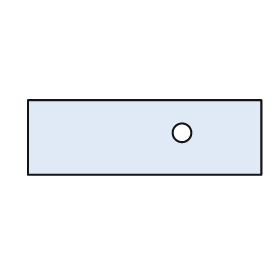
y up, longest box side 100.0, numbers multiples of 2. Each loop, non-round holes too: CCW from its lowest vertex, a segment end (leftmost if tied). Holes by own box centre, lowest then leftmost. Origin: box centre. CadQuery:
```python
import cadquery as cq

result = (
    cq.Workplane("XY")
    .moveTo(-50.0, -16.0)
    .lineTo(50.0, -16.0)
    .lineTo(50.0, 16.0)
    .lineTo(-50.0, 16.0)
    .close()
    .moveTo(16.0, 2.0)
    .circle(4.0)
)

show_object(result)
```